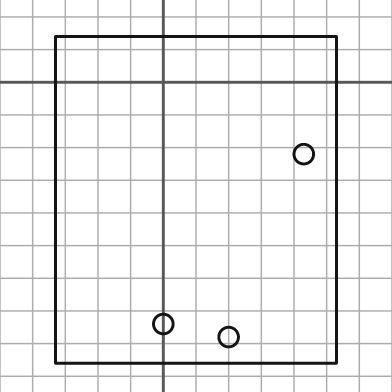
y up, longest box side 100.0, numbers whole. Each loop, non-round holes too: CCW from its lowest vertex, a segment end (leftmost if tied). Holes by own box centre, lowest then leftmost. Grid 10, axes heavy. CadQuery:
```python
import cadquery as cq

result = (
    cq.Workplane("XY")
    .moveTo(-33.0, -86.0)
    .lineTo(53.0, -86.0)
    .lineTo(53.0, 14.0)
    .lineTo(-33.0, 14.0)
    .close()
    .moveTo(20.0, -78.0)
    .circle(3.0)
    .moveTo(0.0, -74.0)
    .circle(3.0)
    .moveTo(43.0, -22.0)
    .circle(3.0)
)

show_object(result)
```